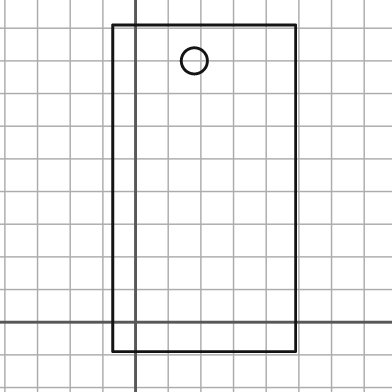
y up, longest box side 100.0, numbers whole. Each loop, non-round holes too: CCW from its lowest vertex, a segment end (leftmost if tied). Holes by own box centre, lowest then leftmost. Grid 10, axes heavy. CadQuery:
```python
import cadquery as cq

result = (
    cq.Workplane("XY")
    .moveTo(-7.0, -9.0)
    .lineTo(49.0, -9.0)
    .lineTo(49.0, 91.0)
    .lineTo(-7.0, 91.0)
    .close()
    .moveTo(18.0, 80.0)
    .circle(4.0)
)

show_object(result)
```